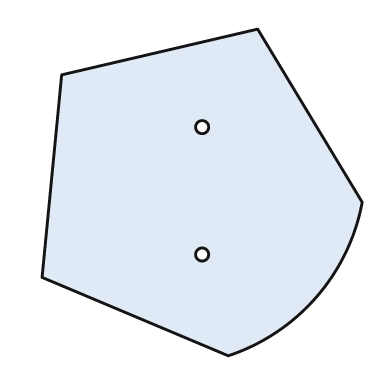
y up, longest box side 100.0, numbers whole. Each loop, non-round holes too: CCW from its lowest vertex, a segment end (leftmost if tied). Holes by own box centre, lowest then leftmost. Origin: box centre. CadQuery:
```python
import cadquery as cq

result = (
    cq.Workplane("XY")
    .moveTo(8.0, -50.0)
    .threePointArc((35.0, -32.0), (49.0, -3.0))
    .lineTo(17.0, 50.0)
    .lineTo(-43.0, 36.0)
    .lineTo(-49.0, -26.0)
    .close()
    .moveTo(0.0, -19.0)
    .circle(2.0)
    .moveTo(0.0, 20.0)
    .circle(2.0)
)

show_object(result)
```